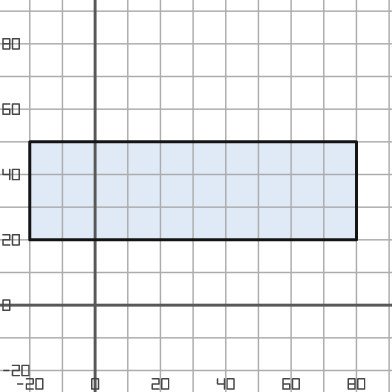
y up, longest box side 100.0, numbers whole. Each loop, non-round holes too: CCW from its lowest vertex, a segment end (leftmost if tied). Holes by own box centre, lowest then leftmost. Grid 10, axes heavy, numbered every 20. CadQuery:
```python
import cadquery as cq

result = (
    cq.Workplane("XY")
    .moveTo(-20.0, 20.0)
    .lineTo(80.0, 20.0)
    .lineTo(80.0, 50.0)
    .lineTo(-20.0, 50.0)
    .close()
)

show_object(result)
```